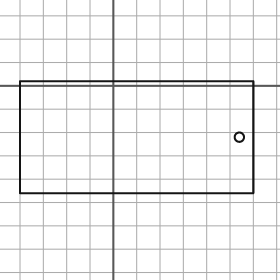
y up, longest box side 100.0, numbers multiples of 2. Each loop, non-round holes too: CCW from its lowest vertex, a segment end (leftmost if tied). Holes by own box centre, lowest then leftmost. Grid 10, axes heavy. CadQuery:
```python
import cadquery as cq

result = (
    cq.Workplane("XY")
    .moveTo(-40.0, -46.0)
    .lineTo(60.0, -46.0)
    .lineTo(60.0, 2.0)
    .lineTo(-40.0, 2.0)
    .close()
    .moveTo(54.0, -22.0)
    .circle(2.0)
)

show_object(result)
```